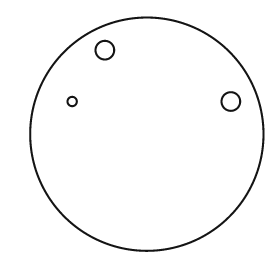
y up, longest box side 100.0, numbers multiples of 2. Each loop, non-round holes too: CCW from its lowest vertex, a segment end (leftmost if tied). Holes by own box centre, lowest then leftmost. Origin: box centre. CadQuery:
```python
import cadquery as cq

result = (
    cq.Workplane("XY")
    .moveTo(0.0, 0.0)
    .circle(50.0)
    .moveTo(-32.0, 14.0)
    .circle(2.0)
    .moveTo(36.0, 14.0)
    .circle(4.0)
    .moveTo(-18.0, 36.0)
    .circle(4.0)
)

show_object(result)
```